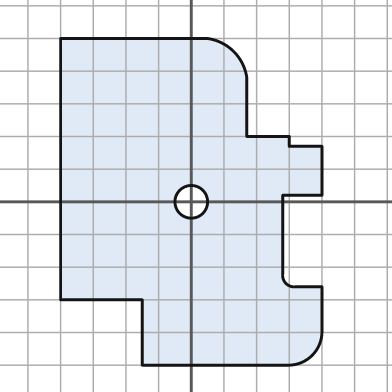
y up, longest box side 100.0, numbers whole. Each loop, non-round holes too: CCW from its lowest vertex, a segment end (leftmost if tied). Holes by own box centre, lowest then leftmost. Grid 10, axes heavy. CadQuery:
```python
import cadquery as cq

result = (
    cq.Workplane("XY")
    .moveTo(-15.0, -50.0)
    .lineTo(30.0, -50.0)
    .threePointArc((37.0, -47.0), (40.0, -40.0))
    .lineTo(40.0, -26.0)
    .lineTo(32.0, -26.0)
    .threePointArc((29.0, -25.0), (28.0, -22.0))
    .lineTo(28.0, 2.0)
    .lineTo(40.0, 2.0)
    .lineTo(40.0, 17.0)
    .lineTo(30.0, 17.0)
    .lineTo(30.0, 20.0)
    .lineTo(17.0, 20.0)
    .lineTo(17.0, 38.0)
    .threePointArc((13.0, 46.0), (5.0, 50.0))
    .lineTo(-40.0, 50.0)
    .lineTo(-40.0, -30.0)
    .lineTo(-15.0, -30.0)
    .close()
    .moveTo(0.0, 0.0)
    .circle(5.0)
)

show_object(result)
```